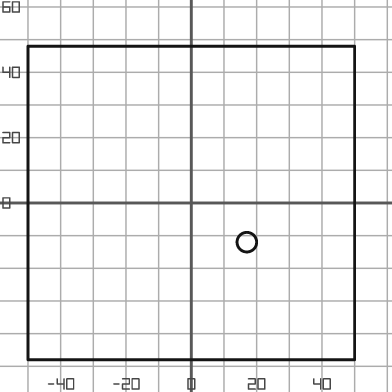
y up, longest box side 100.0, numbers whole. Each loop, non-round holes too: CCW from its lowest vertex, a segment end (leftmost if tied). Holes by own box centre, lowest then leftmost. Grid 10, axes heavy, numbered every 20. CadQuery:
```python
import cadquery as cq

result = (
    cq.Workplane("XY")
    .moveTo(-50.0, -48.0)
    .lineTo(50.0, -48.0)
    .lineTo(50.0, 48.0)
    .lineTo(-50.0, 48.0)
    .close()
    .moveTo(17.0, -12.0)
    .circle(3.0)
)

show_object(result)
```